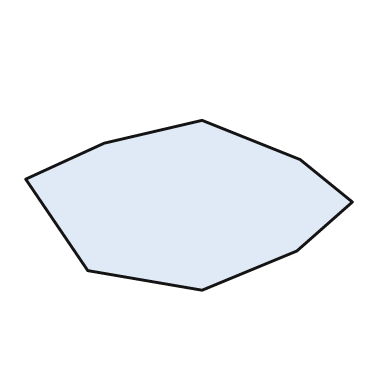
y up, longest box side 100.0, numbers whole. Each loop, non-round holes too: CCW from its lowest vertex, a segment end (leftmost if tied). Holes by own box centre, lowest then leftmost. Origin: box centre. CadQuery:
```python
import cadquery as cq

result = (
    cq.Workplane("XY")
    .moveTo(4.0, -26.0)
    .lineTo(33.0, -14.0)
    .lineTo(50.0, 1.0)
    .lineTo(34.0, 14.0)
    .lineTo(4.0, 26.0)
    .lineTo(-26.0, 19.0)
    .lineTo(-50.0, 8.0)
    .lineTo(-31.0, -20.0)
    .close()
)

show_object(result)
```